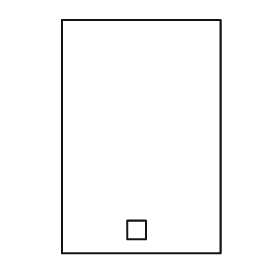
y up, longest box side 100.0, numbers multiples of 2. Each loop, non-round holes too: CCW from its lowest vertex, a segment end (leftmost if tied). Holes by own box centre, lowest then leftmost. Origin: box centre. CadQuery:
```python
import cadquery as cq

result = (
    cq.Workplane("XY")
    .moveTo(-34.0, -50.0)
    .lineTo(34.0, -50.0)
    .lineTo(34.0, 50.0)
    .lineTo(-34.0, 50.0)
    .close()
    .moveTo(-6.0, -44.0)
    .lineTo(2.0, -44.0)
    .lineTo(2.0, -36.0)
    .lineTo(-6.0, -36.0)
    .close()
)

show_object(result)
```